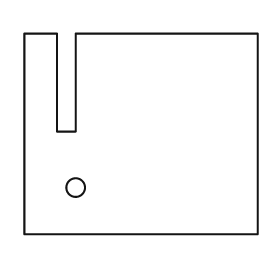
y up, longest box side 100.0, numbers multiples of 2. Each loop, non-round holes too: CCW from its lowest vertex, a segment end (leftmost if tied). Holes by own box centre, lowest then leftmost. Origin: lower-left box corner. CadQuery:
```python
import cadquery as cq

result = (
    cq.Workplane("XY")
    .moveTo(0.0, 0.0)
    .lineTo(100.0, 0.0)
    .lineTo(100.0, 86.0)
    .lineTo(22.0, 86.0)
    .lineTo(22.0, 44.0)
    .lineTo(14.0, 44.0)
    .lineTo(14.0, 86.0)
    .lineTo(0.0, 86.0)
    .close()
    .moveTo(22.0, 20.0)
    .circle(4.0)
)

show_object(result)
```